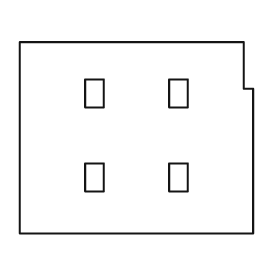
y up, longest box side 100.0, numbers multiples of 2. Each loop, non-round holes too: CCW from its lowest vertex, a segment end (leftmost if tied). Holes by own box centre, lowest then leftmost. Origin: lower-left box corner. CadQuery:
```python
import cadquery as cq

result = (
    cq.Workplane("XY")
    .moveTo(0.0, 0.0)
    .lineTo(100.0, 0.0)
    .lineTo(100.0, 62.0)
    .lineTo(96.0, 62.0)
    .lineTo(96.0, 82.0)
    .lineTo(0.0, 82.0)
    .close()
    .moveTo(28.0, 18.0)
    .lineTo(36.0, 18.0)
    .lineTo(36.0, 30.0)
    .lineTo(28.0, 30.0)
    .close()
    .moveTo(64.0, 18.0)
    .lineTo(72.0, 18.0)
    .lineTo(72.0, 30.0)
    .lineTo(64.0, 30.0)
    .close()
    .moveTo(28.0, 54.0)
    .lineTo(36.0, 54.0)
    .lineTo(36.0, 66.0)
    .lineTo(28.0, 66.0)
    .close()
    .moveTo(64.0, 54.0)
    .lineTo(72.0, 54.0)
    .lineTo(72.0, 66.0)
    .lineTo(64.0, 66.0)
    .close()
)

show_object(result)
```